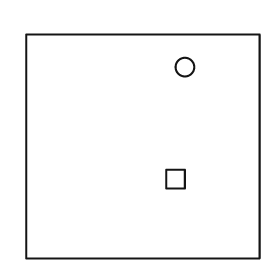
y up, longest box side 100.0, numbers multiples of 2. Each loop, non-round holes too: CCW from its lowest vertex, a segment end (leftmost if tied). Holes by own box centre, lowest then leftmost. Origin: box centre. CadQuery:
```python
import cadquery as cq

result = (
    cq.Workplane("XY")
    .moveTo(-50.0, -48.0)
    .lineTo(50.0, -48.0)
    .lineTo(50.0, 48.0)
    .lineTo(-50.0, 48.0)
    .close()
    .moveTo(10.0, -18.0)
    .lineTo(18.0, -18.0)
    .lineTo(18.0, -10.0)
    .lineTo(10.0, -10.0)
    .close()
    .moveTo(18.0, 34.0)
    .circle(4.0)
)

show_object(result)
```